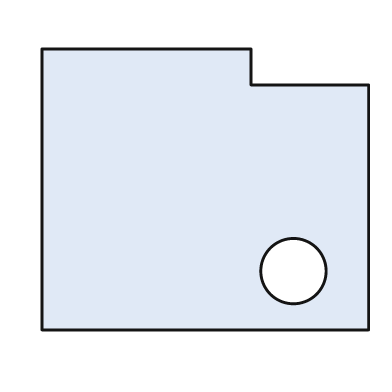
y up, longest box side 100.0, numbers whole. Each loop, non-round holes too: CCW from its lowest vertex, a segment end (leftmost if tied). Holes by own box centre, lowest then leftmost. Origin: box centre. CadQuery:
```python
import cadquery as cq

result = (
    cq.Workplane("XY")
    .moveTo(-50.0, -43.0)
    .lineTo(50.0, -43.0)
    .lineTo(50.0, 32.0)
    .lineTo(14.0, 32.0)
    .lineTo(14.0, 43.0)
    .lineTo(-50.0, 43.0)
    .close()
    .moveTo(27.0, -25.0)
    .circle(10.0)
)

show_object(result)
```